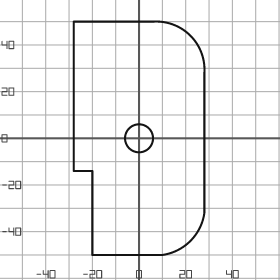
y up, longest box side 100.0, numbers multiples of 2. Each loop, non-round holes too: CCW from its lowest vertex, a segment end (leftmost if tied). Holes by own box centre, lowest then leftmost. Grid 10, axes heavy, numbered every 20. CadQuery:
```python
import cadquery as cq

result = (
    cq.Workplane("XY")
    .moveTo(-20.0, -50.0)
    .lineTo(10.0, -50.0)
    .threePointArc((22.0, -44.0), (28.0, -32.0))
    .lineTo(28.0, 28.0)
    .threePointArc((22.0, 44.0), (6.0, 50.0))
    .lineTo(-28.0, 50.0)
    .lineTo(-28.0, -14.0)
    .lineTo(-20.0, -14.0)
    .close()
    .moveTo(0.0, 0.0)
    .circle(6.0)
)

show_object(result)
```